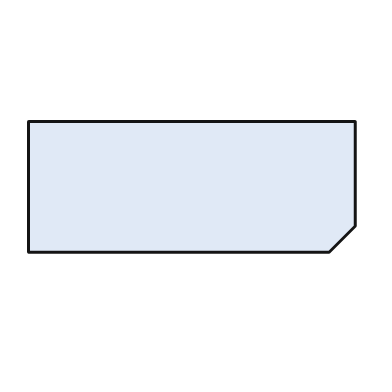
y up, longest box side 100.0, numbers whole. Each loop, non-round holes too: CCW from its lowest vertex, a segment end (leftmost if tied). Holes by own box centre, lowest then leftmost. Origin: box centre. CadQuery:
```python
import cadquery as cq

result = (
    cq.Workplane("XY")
    .moveTo(-50.0, -20.0)
    .lineTo(42.0, -20.0)
    .lineTo(50.0, -12.0)
    .lineTo(50.0, 20.0)
    .lineTo(-50.0, 20.0)
    .close()
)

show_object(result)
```